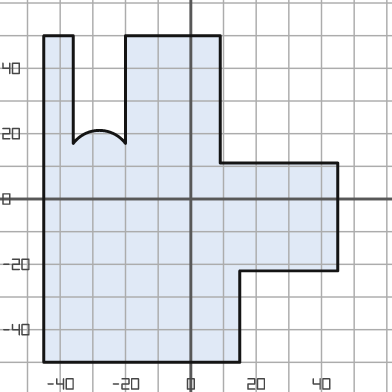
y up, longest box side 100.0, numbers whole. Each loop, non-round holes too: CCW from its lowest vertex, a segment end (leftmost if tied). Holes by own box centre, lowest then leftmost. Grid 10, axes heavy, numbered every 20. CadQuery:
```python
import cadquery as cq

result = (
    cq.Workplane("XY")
    .moveTo(-45.0, -50.0)
    .lineTo(15.0, -50.0)
    .lineTo(15.0, -22.0)
    .lineTo(45.0, -22.0)
    .lineTo(45.0, 11.0)
    .lineTo(9.0, 11.0)
    .lineTo(9.0, 50.0)
    .lineTo(-20.0, 50.0)
    .lineTo(-20.0, 17.0)
    .threePointArc((-28.0, 21.0), (-36.0, 17.0))
    .lineTo(-36.0, 50.0)
    .lineTo(-45.0, 50.0)
    .close()
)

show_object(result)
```